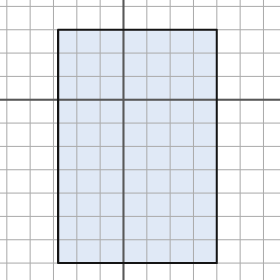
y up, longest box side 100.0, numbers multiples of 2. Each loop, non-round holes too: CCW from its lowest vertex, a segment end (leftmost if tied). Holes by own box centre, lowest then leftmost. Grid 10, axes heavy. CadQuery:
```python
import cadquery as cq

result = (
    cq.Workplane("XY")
    .moveTo(-28.0, -70.0)
    .lineTo(40.0, -70.0)
    .lineTo(40.0, 30.0)
    .lineTo(-28.0, 30.0)
    .close()
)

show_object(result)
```